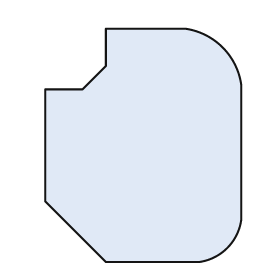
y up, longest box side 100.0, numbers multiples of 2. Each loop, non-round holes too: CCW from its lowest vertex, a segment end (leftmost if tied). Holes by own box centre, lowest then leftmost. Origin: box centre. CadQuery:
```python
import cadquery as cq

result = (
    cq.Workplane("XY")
    .moveTo(-16.0, -50.0)
    .lineTo(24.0, -50.0)
    .threePointArc((36.0, -44.0), (42.0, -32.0))
    .lineTo(42.0, 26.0)
    .threePointArc((34.0, 42.0), (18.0, 50.0))
    .lineTo(-16.0, 50.0)
    .lineTo(-16.0, 34.0)
    .lineTo(-26.0, 24.0)
    .lineTo(-42.0, 24.0)
    .lineTo(-42.0, -24.0)
    .close()
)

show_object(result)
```